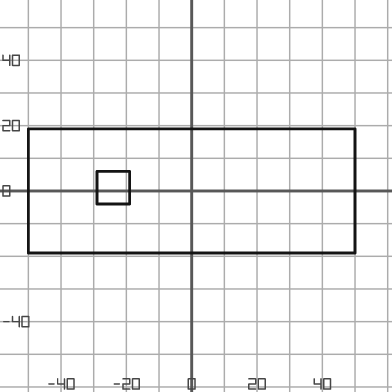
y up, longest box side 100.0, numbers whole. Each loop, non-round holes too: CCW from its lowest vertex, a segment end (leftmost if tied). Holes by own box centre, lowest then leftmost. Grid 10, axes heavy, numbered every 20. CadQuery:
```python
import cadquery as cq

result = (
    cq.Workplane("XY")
    .moveTo(-50.0, -19.0)
    .lineTo(50.0, -19.0)
    .lineTo(50.0, 19.0)
    .lineTo(-50.0, 19.0)
    .close()
    .moveTo(-29.0, -4.0)
    .lineTo(-19.0, -4.0)
    .lineTo(-19.0, 6.0)
    .lineTo(-29.0, 6.0)
    .close()
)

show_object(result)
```